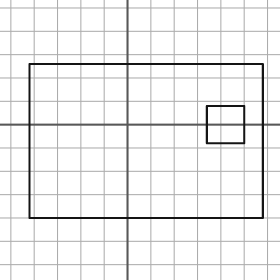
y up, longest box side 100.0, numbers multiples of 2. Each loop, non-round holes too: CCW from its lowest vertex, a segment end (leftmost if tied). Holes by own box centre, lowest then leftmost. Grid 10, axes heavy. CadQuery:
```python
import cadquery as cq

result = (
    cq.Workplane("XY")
    .moveTo(-42.0, -40.0)
    .lineTo(58.0, -40.0)
    .lineTo(58.0, 26.0)
    .lineTo(-42.0, 26.0)
    .close()
    .moveTo(34.0, -8.0)
    .lineTo(50.0, -8.0)
    .lineTo(50.0, 8.0)
    .lineTo(34.0, 8.0)
    .close()
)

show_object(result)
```